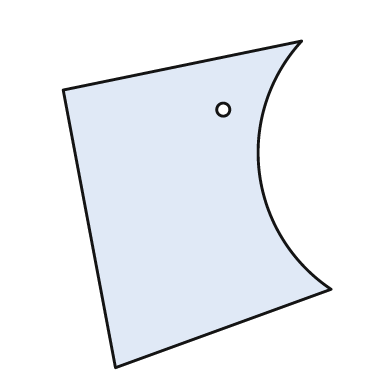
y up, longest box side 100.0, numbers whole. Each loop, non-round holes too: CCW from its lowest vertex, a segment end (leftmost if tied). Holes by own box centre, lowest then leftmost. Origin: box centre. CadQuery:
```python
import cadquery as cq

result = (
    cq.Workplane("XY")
    .moveTo(-25.0, -50.0)
    .lineTo(41.0, -26.0)
    .threePointArc((19.0, 10.0), (32.0, 50.0))
    .lineTo(-41.0, 35.0)
    .close()
    .moveTo(8.0, 29.0)
    .circle(2.0)
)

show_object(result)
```